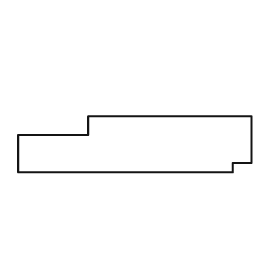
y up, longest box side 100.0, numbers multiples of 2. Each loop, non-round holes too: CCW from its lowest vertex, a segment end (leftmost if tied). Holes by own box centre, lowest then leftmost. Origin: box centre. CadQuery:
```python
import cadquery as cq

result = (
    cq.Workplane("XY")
    .moveTo(-50.0, -12.0)
    .lineTo(42.0, -12.0)
    .lineTo(42.0, -8.0)
    .lineTo(50.0, -8.0)
    .lineTo(50.0, 12.0)
    .lineTo(-20.0, 12.0)
    .lineTo(-20.0, 4.0)
    .lineTo(-50.0, 4.0)
    .close()
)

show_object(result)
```